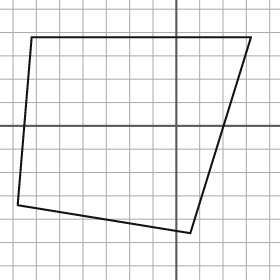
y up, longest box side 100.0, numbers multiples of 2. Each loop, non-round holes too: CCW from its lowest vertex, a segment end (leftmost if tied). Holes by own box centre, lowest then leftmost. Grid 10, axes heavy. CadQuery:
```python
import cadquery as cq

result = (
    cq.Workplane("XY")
    .moveTo(6.0, -46.0)
    .lineTo(32.0, 38.0)
    .lineTo(-62.0, 38.0)
    .lineTo(-68.0, -34.0)
    .close()
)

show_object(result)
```